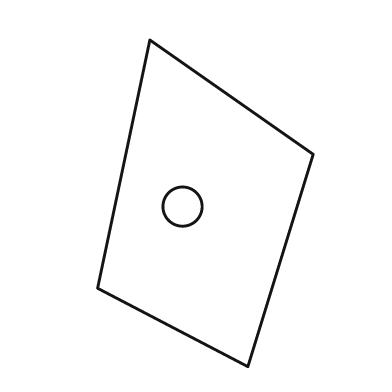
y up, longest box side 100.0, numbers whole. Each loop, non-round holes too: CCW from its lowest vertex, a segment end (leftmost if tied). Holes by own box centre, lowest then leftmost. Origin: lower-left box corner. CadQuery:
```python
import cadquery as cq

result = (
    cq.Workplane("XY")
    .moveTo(46.0, 0.0)
    .lineTo(66.0, 65.0)
    .lineTo(16.0, 100.0)
    .lineTo(0.0, 24.0)
    .close()
    .moveTo(26.0, 49.0)
    .circle(6.0)
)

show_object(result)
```